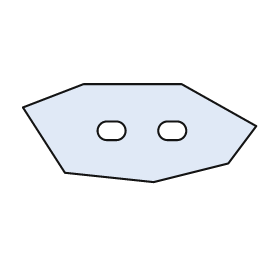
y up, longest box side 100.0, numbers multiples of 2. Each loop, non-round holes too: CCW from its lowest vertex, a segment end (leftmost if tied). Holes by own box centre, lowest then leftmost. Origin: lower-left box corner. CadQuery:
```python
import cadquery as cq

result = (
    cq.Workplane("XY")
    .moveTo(56.0, 0.0)
    .lineTo(88.0, 8.0)
    .lineTo(100.0, 24.0)
    .lineTo(68.0, 42.0)
    .lineTo(26.0, 42.0)
    .lineTo(0.0, 32.0)
    .lineTo(18.0, 4.0)
    .close()
    .moveTo(36.0, 18.0)
    .lineTo(40.0, 18.0)
    .threePointArc((44.0, 22.0), (40.0, 26.0))
    .lineTo(36.0, 26.0)
    .threePointArc((32.0, 22.0), (36.0, 18.0))
    .close()
    .moveTo(62.0, 18.0)
    .lineTo(66.0, 18.0)
    .threePointArc((70.0, 22.0), (66.0, 26.0))
    .lineTo(62.0, 26.0)
    .threePointArc((58.0, 22.0), (62.0, 18.0))
    .close()
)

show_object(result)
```